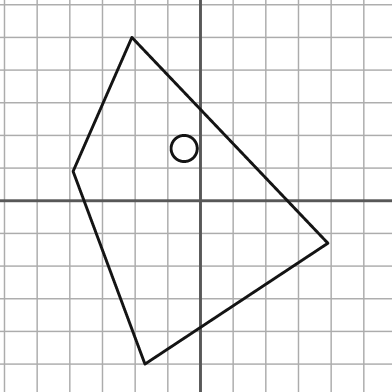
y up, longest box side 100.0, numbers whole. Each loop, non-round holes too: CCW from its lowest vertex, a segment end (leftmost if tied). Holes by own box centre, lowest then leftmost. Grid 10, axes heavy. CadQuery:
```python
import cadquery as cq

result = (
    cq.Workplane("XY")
    .moveTo(-17.0, -50.0)
    .lineTo(39.0, -13.0)
    .lineTo(-21.0, 50.0)
    .lineTo(-39.0, 9.0)
    .close()
    .moveTo(-5.0, 16.0)
    .circle(4.0)
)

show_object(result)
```